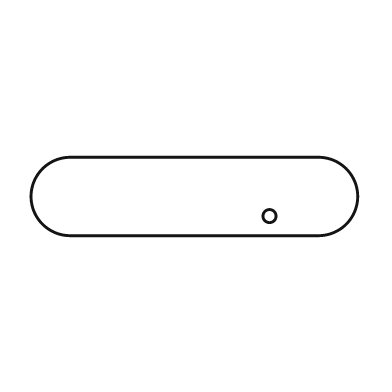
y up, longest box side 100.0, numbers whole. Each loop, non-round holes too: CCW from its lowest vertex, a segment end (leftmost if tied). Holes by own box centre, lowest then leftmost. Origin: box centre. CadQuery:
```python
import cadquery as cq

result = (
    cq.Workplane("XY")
    .moveTo(-38.0, -12.0)
    .lineTo(38.0, -12.0)
    .threePointArc((50.0, 0.0), (38.0, 12.0))
    .lineTo(-38.0, 12.0)
    .threePointArc((-50.0, 0.0), (-38.0, -12.0))
    .close()
    .moveTo(23.0, -6.0)
    .circle(2.0)
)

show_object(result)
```